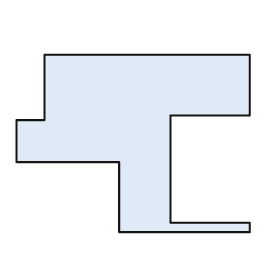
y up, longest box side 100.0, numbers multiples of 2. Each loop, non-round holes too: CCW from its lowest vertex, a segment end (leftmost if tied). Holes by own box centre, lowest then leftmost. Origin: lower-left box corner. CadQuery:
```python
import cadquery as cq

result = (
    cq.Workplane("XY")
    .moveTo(44.0, 0.0)
    .lineTo(100.0, 0.0)
    .lineTo(100.0, 4.0)
    .lineTo(66.0, 4.0)
    .lineTo(66.0, 50.0)
    .lineTo(100.0, 50.0)
    .lineTo(100.0, 76.0)
    .lineTo(12.0, 76.0)
    .lineTo(12.0, 48.0)
    .lineTo(0.0, 48.0)
    .lineTo(0.0, 30.0)
    .lineTo(44.0, 30.0)
    .close()
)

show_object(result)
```